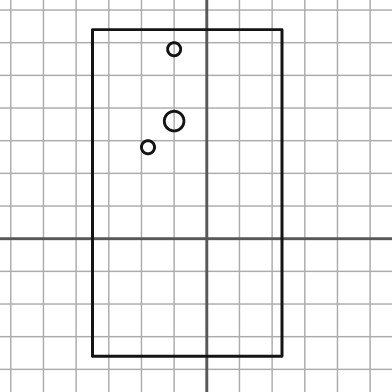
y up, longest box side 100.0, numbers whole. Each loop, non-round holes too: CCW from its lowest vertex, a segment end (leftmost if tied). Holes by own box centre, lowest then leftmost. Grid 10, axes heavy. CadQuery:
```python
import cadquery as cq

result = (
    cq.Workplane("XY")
    .moveTo(-35.0, -36.0)
    .lineTo(23.0, -36.0)
    .lineTo(23.0, 64.0)
    .lineTo(-35.0, 64.0)
    .close()
    .moveTo(-18.0, 28.0)
    .circle(2.0)
    .moveTo(-10.0, 36.0)
    .circle(3.0)
    .moveTo(-10.0, 58.0)
    .circle(2.0)
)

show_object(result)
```